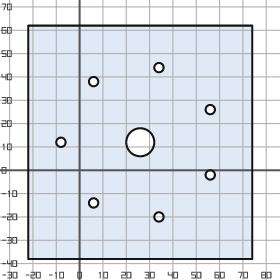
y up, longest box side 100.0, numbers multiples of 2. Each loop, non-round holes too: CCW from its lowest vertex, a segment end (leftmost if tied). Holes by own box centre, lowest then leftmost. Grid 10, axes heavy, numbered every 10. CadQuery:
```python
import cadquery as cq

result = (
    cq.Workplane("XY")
    .moveTo(-22.0, -38.0)
    .lineTo(74.0, -38.0)
    .lineTo(74.0, 62.0)
    .lineTo(-22.0, 62.0)
    .close()
    .moveTo(34.0, -20.0)
    .circle(2.0)
    .moveTo(6.0, -14.0)
    .circle(2.0)
    .moveTo(56.0, -2.0)
    .circle(2.0)
    .moveTo(-8.0, 12.0)
    .circle(2.0)
    .moveTo(26.0, 12.0)
    .circle(6.0)
    .moveTo(56.0, 26.0)
    .circle(2.0)
    .moveTo(6.0, 38.0)
    .circle(2.0)
    .moveTo(34.0, 44.0)
    .circle(2.0)
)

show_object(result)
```